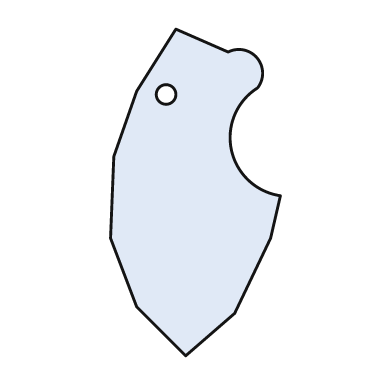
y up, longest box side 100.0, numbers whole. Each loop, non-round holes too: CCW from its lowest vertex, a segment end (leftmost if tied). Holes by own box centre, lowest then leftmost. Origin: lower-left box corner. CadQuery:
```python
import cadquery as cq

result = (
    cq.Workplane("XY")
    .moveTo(23.0, 0.0)
    .lineTo(38.0, 13.0)
    .lineTo(49.0, 36.0)
    .lineTo(52.0, 49.0)
    .threePointArc((37.0, 63.0), (45.0, 82.0))
    .threePointArc((45.0, 91.0), (36.0, 93.0))
    .lineTo(20.0, 100.0)
    .lineTo(8.0, 81.0)
    .lineTo(1.0, 61.0)
    .lineTo(0.0, 36.0)
    .lineTo(8.0, 15.0)
    .close()
    .moveTo(17.0, 80.0)
    .circle(3.0)
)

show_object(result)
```